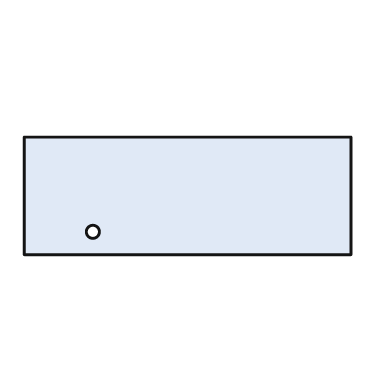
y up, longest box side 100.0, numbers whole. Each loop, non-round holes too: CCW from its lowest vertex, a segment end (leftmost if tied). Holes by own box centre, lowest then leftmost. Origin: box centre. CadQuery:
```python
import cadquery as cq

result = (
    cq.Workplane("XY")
    .moveTo(-50.0, -18.0)
    .lineTo(50.0, -18.0)
    .lineTo(50.0, 18.0)
    .lineTo(-50.0, 18.0)
    .close()
    .moveTo(-29.0, -11.0)
    .circle(2.0)
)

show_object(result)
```